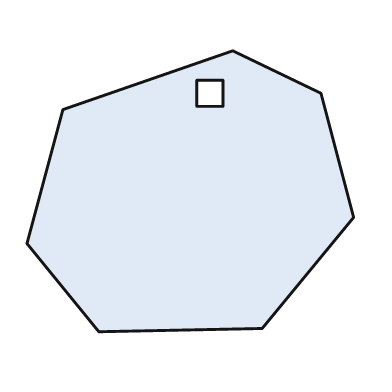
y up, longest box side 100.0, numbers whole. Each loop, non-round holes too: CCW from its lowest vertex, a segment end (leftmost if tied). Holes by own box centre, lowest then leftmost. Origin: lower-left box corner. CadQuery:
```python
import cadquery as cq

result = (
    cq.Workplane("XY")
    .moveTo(22.0, 0.0)
    .lineTo(72.0, 1.0)
    .lineTo(100.0, 35.0)
    .lineTo(90.0, 73.0)
    .lineTo(63.0, 86.0)
    .lineTo(11.0, 68.0)
    .lineTo(0.0, 27.0)
    .close()
    .moveTo(52.0, 69.0)
    .lineTo(60.0, 69.0)
    .lineTo(60.0, 77.0)
    .lineTo(52.0, 77.0)
    .close()
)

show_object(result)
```